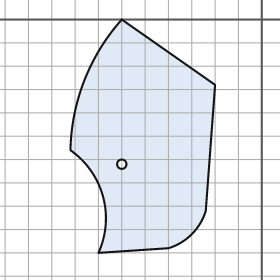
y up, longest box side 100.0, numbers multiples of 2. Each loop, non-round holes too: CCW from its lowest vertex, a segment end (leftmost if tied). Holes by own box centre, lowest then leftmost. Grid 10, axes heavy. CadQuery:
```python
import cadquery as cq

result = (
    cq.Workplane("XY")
    .moveTo(-70.0, -100.0)
    .lineTo(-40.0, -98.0)
    .threePointArc((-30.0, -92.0), (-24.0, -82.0))
    .lineTo(-20.0, -28.0)
    .lineTo(-60.0, 0.0)
    .threePointArc((-76.0, -26.0), (-82.0, -56.0))
    .threePointArc((-68.0, -76.0), (-70.0, -100.0))
    .close()
    .moveTo(-60.0, -62.0)
    .circle(2.0)
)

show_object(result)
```